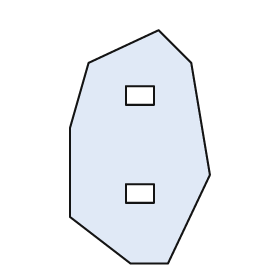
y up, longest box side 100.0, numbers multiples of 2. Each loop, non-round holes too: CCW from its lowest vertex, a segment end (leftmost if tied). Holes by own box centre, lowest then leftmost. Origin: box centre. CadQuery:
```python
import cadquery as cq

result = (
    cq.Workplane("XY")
    .moveTo(-4.0, -50.0)
    .lineTo(12.0, -50.0)
    .lineTo(30.0, -12.0)
    .lineTo(22.0, 36.0)
    .lineTo(8.0, 50.0)
    .lineTo(-22.0, 36.0)
    .lineTo(-30.0, 8.0)
    .lineTo(-30.0, -30.0)
    .close()
    .moveTo(-6.0, -24.0)
    .lineTo(6.0, -24.0)
    .lineTo(6.0, -16.0)
    .lineTo(-6.0, -16.0)
    .close()
    .moveTo(-6.0, 18.0)
    .lineTo(6.0, 18.0)
    .lineTo(6.0, 26.0)
    .lineTo(-6.0, 26.0)
    .close()
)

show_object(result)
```